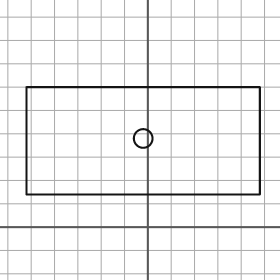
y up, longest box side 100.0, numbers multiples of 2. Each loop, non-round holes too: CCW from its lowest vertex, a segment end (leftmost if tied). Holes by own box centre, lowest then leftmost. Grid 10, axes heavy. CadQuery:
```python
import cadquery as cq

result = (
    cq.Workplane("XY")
    .moveTo(-52.0, 14.0)
    .lineTo(48.0, 14.0)
    .lineTo(48.0, 60.0)
    .lineTo(-52.0, 60.0)
    .close()
    .moveTo(-2.0, 38.0)
    .circle(4.0)
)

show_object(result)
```